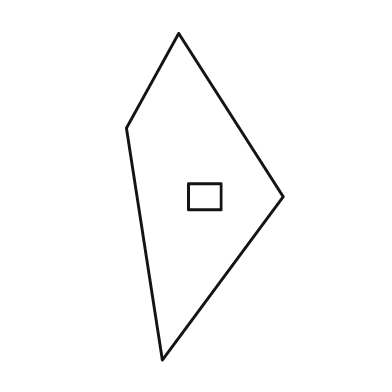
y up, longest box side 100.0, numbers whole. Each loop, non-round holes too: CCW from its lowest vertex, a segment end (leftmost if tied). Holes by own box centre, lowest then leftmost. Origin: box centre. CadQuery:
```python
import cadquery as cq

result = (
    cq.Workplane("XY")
    .moveTo(-13.0, -50.0)
    .lineTo(24.0, 0.0)
    .lineTo(-8.0, 50.0)
    .lineTo(-24.0, 21.0)
    .close()
    .moveTo(-5.0, -4.0)
    .lineTo(5.0, -4.0)
    .lineTo(5.0, 4.0)
    .lineTo(-5.0, 4.0)
    .close()
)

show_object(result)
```